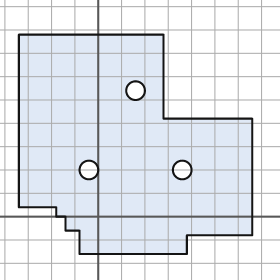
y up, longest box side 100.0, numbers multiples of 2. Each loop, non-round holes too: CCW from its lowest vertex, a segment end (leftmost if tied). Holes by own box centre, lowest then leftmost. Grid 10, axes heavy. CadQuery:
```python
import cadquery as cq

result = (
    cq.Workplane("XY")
    .moveTo(-8.0, -16.0)
    .lineTo(38.0, -16.0)
    .lineTo(38.0, -8.0)
    .lineTo(66.0, -8.0)
    .lineTo(66.0, 42.0)
    .lineTo(28.0, 42.0)
    .lineTo(28.0, 78.0)
    .lineTo(-34.0, 78.0)
    .lineTo(-34.0, 4.0)
    .lineTo(-18.0, 4.0)
    .lineTo(-18.0, 0.0)
    .lineTo(-14.0, 0.0)
    .lineTo(-14.0, -6.0)
    .lineTo(-8.0, -6.0)
    .close()
    .moveTo(-4.0, 20.0)
    .circle(4.0)
    .moveTo(36.0, 20.0)
    .circle(4.0)
    .moveTo(16.0, 54.0)
    .circle(4.0)
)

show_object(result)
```